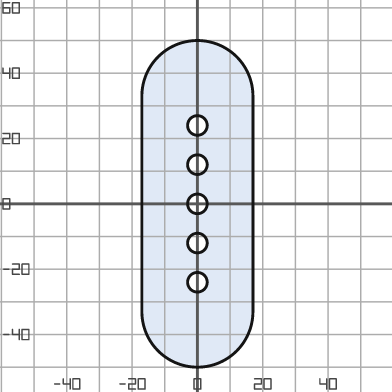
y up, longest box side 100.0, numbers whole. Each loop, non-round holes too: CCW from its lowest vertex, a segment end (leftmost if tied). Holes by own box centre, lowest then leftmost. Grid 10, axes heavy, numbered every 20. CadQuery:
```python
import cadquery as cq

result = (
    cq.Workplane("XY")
    .moveTo(-17.0, -33.0)
    .threePointArc((0.0, -50.0), (17.0, -33.0))
    .lineTo(17.0, 33.0)
    .threePointArc((0.0, 50.0), (-17.0, 33.0))
    .close()
    .moveTo(0.0, -24.0)
    .circle(3.0)
    .moveTo(0.0, -12.0)
    .circle(3.0)
    .moveTo(0.0, 0.0)
    .circle(3.0)
    .moveTo(0.0, 12.0)
    .circle(3.0)
    .moveTo(0.0, 24.0)
    .circle(3.0)
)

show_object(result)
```